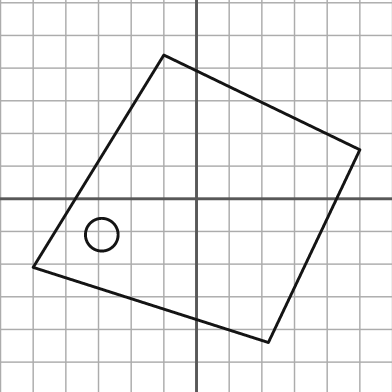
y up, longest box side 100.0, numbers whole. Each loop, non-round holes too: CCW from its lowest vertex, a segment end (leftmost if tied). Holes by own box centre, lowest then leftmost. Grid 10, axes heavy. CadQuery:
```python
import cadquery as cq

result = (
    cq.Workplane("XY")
    .moveTo(22.0, -44.0)
    .lineTo(50.0, 15.0)
    .lineTo(-10.0, 44.0)
    .lineTo(-50.0, -21.0)
    .close()
    .moveTo(-29.0, -11.0)
    .circle(5.0)
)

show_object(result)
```